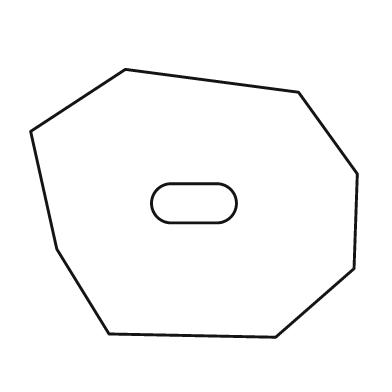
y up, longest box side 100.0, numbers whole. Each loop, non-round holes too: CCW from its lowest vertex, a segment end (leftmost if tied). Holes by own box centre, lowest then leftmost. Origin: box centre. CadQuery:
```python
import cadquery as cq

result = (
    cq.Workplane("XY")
    .moveTo(25.0, -41.0)
    .lineTo(49.0, -20.0)
    .lineTo(50.0, 9.0)
    .lineTo(32.0, 34.0)
    .lineTo(-21.0, 41.0)
    .lineTo(-50.0, 22.0)
    .lineTo(-42.0, -14.0)
    .lineTo(-26.0, -40.0)
    .close()
    .moveTo(-7.0, -6.0)
    .lineTo(7.0, -6.0)
    .threePointArc((13.0, 0.0), (7.0, 6.0))
    .lineTo(-7.0, 6.0)
    .threePointArc((-13.0, 0.0), (-7.0, -6.0))
    .close()
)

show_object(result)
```